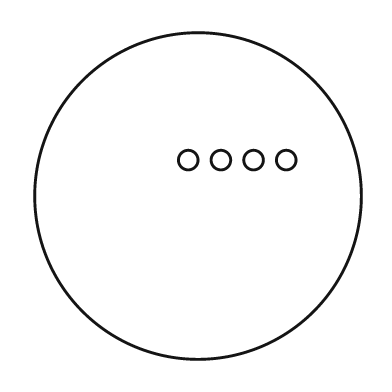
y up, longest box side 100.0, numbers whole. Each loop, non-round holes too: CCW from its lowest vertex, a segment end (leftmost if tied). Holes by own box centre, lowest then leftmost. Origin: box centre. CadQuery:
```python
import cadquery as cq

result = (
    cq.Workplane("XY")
    .moveTo(0.0, 0.0)
    .circle(50.0)
    .moveTo(-3.0, 11.0)
    .circle(3.0)
    .moveTo(7.0, 11.0)
    .circle(3.0)
    .moveTo(17.0, 11.0)
    .circle(3.0)
    .moveTo(27.0, 11.0)
    .circle(3.0)
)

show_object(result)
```